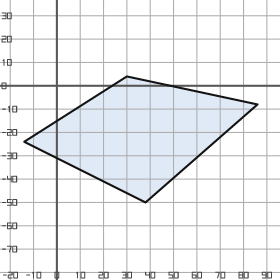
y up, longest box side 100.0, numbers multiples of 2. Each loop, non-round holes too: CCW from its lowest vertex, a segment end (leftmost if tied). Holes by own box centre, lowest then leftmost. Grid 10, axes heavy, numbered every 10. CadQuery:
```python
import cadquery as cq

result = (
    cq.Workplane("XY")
    .moveTo(38.0, -50.0)
    .lineTo(86.0, -8.0)
    .lineTo(30.0, 4.0)
    .lineTo(-14.0, -24.0)
    .close()
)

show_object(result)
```